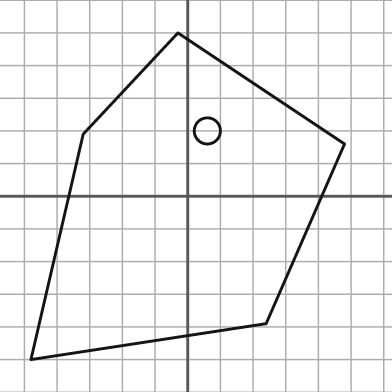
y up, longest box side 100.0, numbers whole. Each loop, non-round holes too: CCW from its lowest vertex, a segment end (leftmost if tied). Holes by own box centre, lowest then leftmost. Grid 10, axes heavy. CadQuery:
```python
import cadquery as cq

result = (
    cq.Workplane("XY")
    .moveTo(-48.0, -50.0)
    .lineTo(24.0, -39.0)
    .lineTo(48.0, 16.0)
    .lineTo(-3.0, 50.0)
    .lineTo(-32.0, 19.0)
    .close()
    .moveTo(6.0, 20.0)
    .circle(4.0)
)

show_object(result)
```